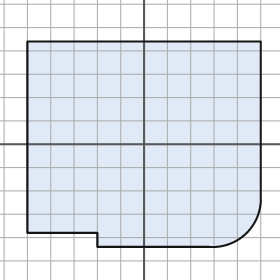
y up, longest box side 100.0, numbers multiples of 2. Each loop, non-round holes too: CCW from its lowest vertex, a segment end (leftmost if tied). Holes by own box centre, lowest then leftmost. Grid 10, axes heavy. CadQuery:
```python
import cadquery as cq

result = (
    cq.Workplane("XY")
    .moveTo(-20.0, -44.0)
    .lineTo(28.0, -44.0)
    .threePointArc((44.0, -38.0), (50.0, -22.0))
    .lineTo(50.0, 44.0)
    .lineTo(-50.0, 44.0)
    .lineTo(-50.0, -38.0)
    .lineTo(-20.0, -38.0)
    .close()
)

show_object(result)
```